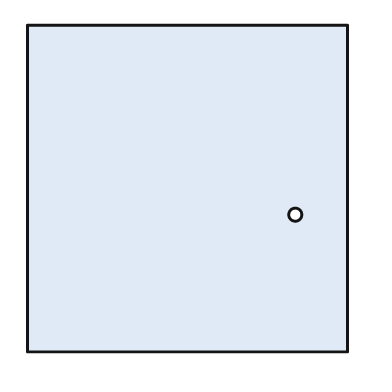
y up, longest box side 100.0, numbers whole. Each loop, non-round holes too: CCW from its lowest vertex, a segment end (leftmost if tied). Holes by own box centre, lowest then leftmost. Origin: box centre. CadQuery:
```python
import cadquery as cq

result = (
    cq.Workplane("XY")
    .moveTo(-49.0, -50.0)
    .lineTo(49.0, -50.0)
    .lineTo(49.0, 50.0)
    .lineTo(-49.0, 50.0)
    .close()
    .moveTo(33.0, -8.0)
    .circle(2.0)
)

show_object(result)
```